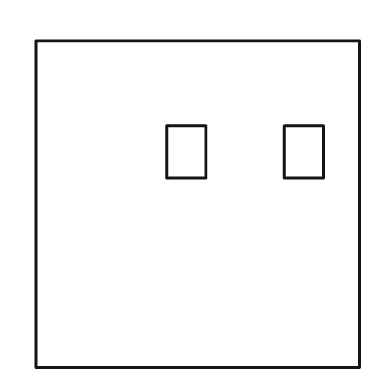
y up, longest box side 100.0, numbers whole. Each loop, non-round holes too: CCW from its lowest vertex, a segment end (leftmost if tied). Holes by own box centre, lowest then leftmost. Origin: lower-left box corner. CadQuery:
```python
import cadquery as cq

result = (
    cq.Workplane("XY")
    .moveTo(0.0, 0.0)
    .lineTo(99.0, 0.0)
    .lineTo(99.0, 100.0)
    .lineTo(0.0, 100.0)
    .close()
    .moveTo(40.0, 58.0)
    .lineTo(52.0, 58.0)
    .lineTo(52.0, 74.0)
    .lineTo(40.0, 74.0)
    .close()
    .moveTo(76.0, 58.0)
    .lineTo(88.0, 58.0)
    .lineTo(88.0, 74.0)
    .lineTo(76.0, 74.0)
    .close()
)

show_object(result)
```